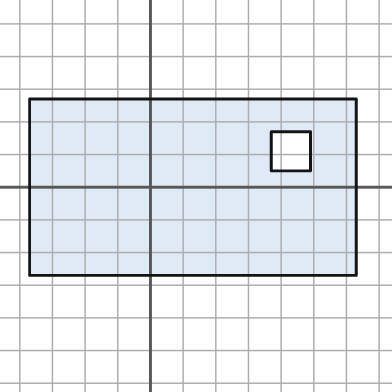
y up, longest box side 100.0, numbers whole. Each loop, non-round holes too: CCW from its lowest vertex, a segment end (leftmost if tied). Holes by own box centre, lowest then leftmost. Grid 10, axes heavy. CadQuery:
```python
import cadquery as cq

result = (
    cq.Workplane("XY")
    .moveTo(-37.0, -27.0)
    .lineTo(63.0, -27.0)
    .lineTo(63.0, 27.0)
    .lineTo(-37.0, 27.0)
    .close()
    .moveTo(37.0, 5.0)
    .lineTo(49.0, 5.0)
    .lineTo(49.0, 17.0)
    .lineTo(37.0, 17.0)
    .close()
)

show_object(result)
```